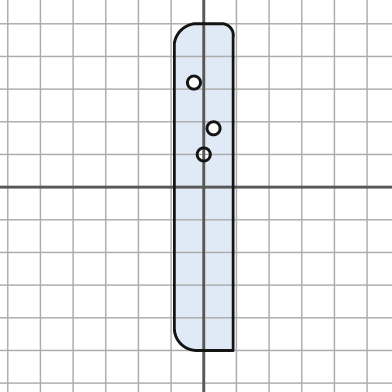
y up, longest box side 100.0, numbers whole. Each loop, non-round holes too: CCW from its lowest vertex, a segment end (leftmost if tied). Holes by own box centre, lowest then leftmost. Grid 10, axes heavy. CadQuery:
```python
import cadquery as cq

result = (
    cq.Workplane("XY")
    .moveTo(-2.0, -50.0)
    .lineTo(9.0, -50.0)
    .lineTo(9.0, 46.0)
    .threePointArc((8.0, 49.0), (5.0, 50.0))
    .lineTo(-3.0, 50.0)
    .threePointArc((-7.0, 48.0), (-9.0, 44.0))
    .lineTo(-9.0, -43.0)
    .threePointArc((-7.0, -48.0), (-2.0, -50.0))
    .close()
    .moveTo(0.0, 10.0)
    .circle(2.0)
    .moveTo(3.0, 18.0)
    .circle(2.0)
    .moveTo(-3.0, 32.0)
    .circle(2.0)
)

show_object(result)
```